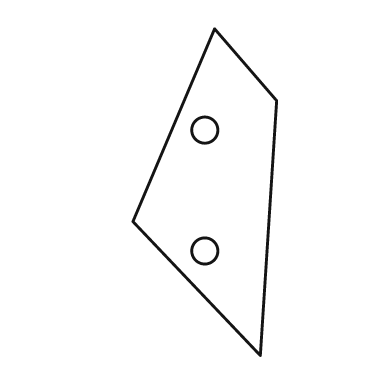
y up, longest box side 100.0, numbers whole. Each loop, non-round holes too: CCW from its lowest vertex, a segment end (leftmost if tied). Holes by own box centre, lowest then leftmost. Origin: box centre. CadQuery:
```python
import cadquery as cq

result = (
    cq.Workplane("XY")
    .moveTo(17.0, -50.0)
    .lineTo(22.0, 28.0)
    .lineTo(3.0, 50.0)
    .lineTo(-22.0, -9.0)
    .close()
    .moveTo(0.0, -18.0)
    .circle(4.0)
    .moveTo(0.0, 19.0)
    .circle(4.0)
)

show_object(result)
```